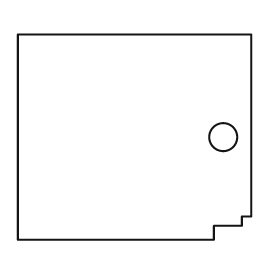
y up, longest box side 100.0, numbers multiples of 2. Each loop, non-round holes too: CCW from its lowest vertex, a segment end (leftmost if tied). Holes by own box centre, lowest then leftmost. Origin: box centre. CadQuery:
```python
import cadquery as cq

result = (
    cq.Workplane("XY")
    .moveTo(-50.0, -44.0)
    .lineTo(34.0, -44.0)
    .lineTo(34.0, -38.0)
    .lineTo(46.0, -38.0)
    .lineTo(46.0, -34.0)
    .lineTo(50.0, -34.0)
    .lineTo(50.0, 44.0)
    .lineTo(-50.0, 44.0)
    .close()
    .moveTo(38.0, 0.0)
    .circle(6.0)
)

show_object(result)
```